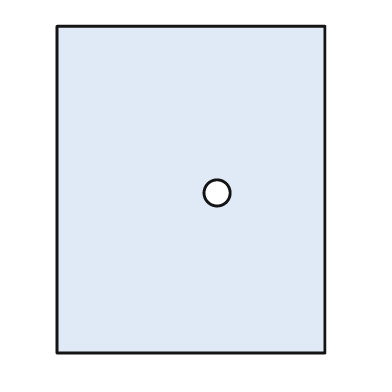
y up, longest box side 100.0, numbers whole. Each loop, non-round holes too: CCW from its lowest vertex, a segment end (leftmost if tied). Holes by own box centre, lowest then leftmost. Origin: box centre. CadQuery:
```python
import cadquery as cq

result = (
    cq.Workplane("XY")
    .moveTo(-41.0, -50.0)
    .lineTo(41.0, -50.0)
    .lineTo(41.0, 50.0)
    .lineTo(-41.0, 50.0)
    .close()
    .moveTo(8.0, -1.0)
    .circle(4.0)
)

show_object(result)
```